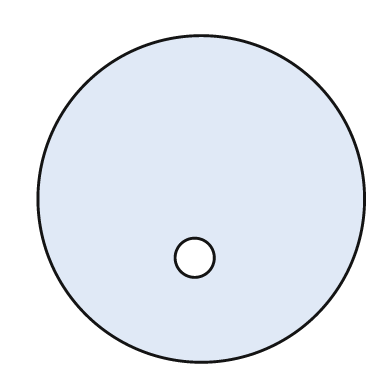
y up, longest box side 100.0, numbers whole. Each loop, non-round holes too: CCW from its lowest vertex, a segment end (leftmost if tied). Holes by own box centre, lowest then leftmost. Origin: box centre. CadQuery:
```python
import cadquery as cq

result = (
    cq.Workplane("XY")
    .moveTo(0.0, 0.0)
    .circle(50.0)
    .moveTo(-2.0, -18.0)
    .circle(6.0)
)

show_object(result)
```